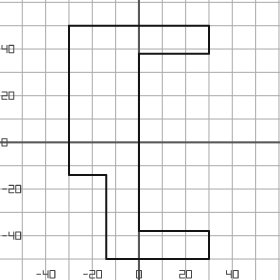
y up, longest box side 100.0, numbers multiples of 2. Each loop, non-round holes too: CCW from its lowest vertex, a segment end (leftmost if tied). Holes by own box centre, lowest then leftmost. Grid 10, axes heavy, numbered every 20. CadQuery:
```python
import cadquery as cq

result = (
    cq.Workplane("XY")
    .moveTo(-14.0, -50.0)
    .lineTo(30.0, -50.0)
    .lineTo(30.0, -38.0)
    .lineTo(0.0, -38.0)
    .lineTo(0.0, 38.0)
    .lineTo(30.0, 38.0)
    .lineTo(30.0, 50.0)
    .lineTo(-30.0, 50.0)
    .lineTo(-30.0, -14.0)
    .lineTo(-14.0, -14.0)
    .close()
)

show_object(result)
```